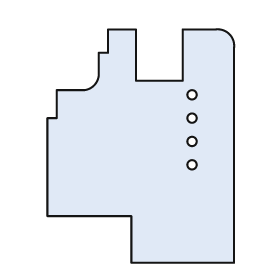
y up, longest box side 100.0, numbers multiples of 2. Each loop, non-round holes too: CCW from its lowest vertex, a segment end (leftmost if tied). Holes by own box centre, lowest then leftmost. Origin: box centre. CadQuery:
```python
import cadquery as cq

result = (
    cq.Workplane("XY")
    .moveTo(-4.0, -50.0)
    .lineTo(40.0, -50.0)
    .lineTo(40.0, 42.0)
    .threePointArc((38.0, 48.0), (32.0, 50.0))
    .lineTo(18.0, 50.0)
    .lineTo(18.0, 28.0)
    .lineTo(-2.0, 28.0)
    .lineTo(-2.0, 50.0)
    .lineTo(-14.0, 50.0)
    .lineTo(-14.0, 40.0)
    .lineTo(-18.0, 40.0)
    .lineTo(-18.0, 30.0)
    .threePointArc((-20.0, 26.0), (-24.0, 24.0))
    .lineTo(-36.0, 24.0)
    .lineTo(-36.0, 12.0)
    .lineTo(-40.0, 12.0)
    .lineTo(-40.0, -30.0)
    .lineTo(-4.0, -30.0)
    .close()
    .moveTo(22.0, -8.0)
    .circle(2.0)
    .moveTo(22.0, 2.0)
    .circle(2.0)
    .moveTo(22.0, 12.0)
    .circle(2.0)
    .moveTo(22.0, 22.0)
    .circle(2.0)
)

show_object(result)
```